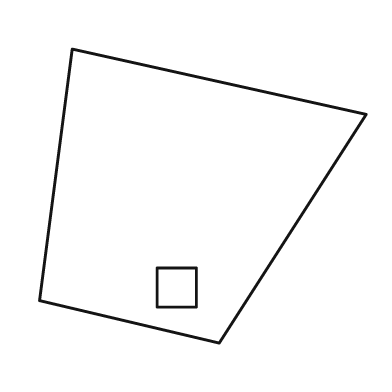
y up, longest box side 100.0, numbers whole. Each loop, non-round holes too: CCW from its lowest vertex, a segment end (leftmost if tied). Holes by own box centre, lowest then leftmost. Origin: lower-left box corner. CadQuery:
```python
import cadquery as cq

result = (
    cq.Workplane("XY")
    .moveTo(55.0, 0.0)
    .lineTo(100.0, 70.0)
    .lineTo(10.0, 90.0)
    .lineTo(0.0, 13.0)
    .close()
    .moveTo(36.0, 11.0)
    .lineTo(48.0, 11.0)
    .lineTo(48.0, 23.0)
    .lineTo(36.0, 23.0)
    .close()
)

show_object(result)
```